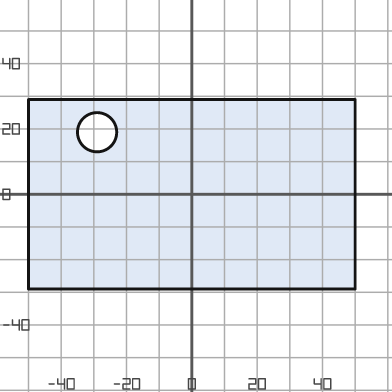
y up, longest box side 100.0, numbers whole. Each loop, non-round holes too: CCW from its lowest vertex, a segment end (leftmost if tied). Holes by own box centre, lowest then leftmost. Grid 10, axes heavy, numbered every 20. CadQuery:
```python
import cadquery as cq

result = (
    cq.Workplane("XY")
    .moveTo(-50.0, -29.0)
    .lineTo(50.0, -29.0)
    .lineTo(50.0, 29.0)
    .lineTo(-50.0, 29.0)
    .close()
    .moveTo(-29.0, 19.0)
    .circle(6.0)
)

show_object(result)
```